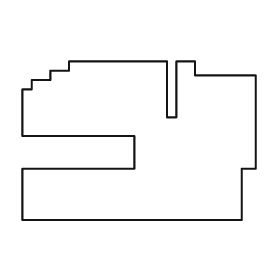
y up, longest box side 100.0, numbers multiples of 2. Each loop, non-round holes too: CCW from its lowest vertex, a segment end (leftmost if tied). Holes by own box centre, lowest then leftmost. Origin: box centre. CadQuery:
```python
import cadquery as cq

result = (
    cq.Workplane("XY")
    .moveTo(-50.0, -34.0)
    .lineTo(44.0, -34.0)
    .lineTo(44.0, -12.0)
    .lineTo(50.0, -12.0)
    .lineTo(50.0, 28.0)
    .lineTo(24.0, 28.0)
    .lineTo(24.0, 34.0)
    .lineTo(16.0, 34.0)
    .lineTo(16.0, 10.0)
    .lineTo(12.0, 10.0)
    .lineTo(12.0, 34.0)
    .lineTo(-30.0, 34.0)
    .lineTo(-30.0, 30.0)
    .lineTo(-38.0, 30.0)
    .lineTo(-38.0, 26.0)
    .lineTo(-46.0, 26.0)
    .lineTo(-46.0, 22.0)
    .lineTo(-50.0, 22.0)
    .lineTo(-50.0, 2.0)
    .lineTo(-2.0, 2.0)
    .lineTo(-2.0, -12.0)
    .lineTo(-50.0, -12.0)
    .close()
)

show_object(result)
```